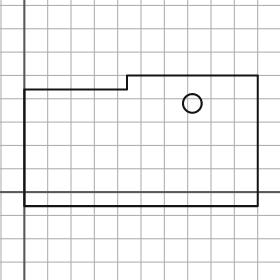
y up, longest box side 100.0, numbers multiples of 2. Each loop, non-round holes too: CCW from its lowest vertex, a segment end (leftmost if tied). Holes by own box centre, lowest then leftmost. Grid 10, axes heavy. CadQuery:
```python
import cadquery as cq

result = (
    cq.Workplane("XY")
    .moveTo(0.0, -6.0)
    .lineTo(100.0, -6.0)
    .lineTo(100.0, 50.0)
    .lineTo(44.0, 50.0)
    .lineTo(44.0, 44.0)
    .lineTo(0.0, 44.0)
    .close()
    .moveTo(72.0, 38.0)
    .circle(4.0)
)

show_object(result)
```